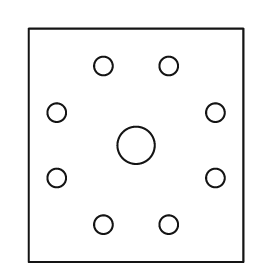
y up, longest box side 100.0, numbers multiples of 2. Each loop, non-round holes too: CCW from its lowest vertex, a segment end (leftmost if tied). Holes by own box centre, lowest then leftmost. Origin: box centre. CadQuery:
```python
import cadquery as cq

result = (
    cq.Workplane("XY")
    .moveTo(-46.0, -50.0)
    .lineTo(46.0, -50.0)
    .lineTo(46.0, 50.0)
    .lineTo(-46.0, 50.0)
    .close()
    .moveTo(-14.0, -34.0)
    .circle(4.0)
    .moveTo(14.0, -34.0)
    .circle(4.0)
    .moveTo(-34.0, -14.0)
    .circle(4.0)
    .moveTo(34.0, -14.0)
    .circle(4.0)
    .moveTo(0.0, 0.0)
    .circle(8.0)
    .moveTo(-34.0, 14.0)
    .circle(4.0)
    .moveTo(34.0, 14.0)
    .circle(4.0)
    .moveTo(-14.0, 34.0)
    .circle(4.0)
    .moveTo(14.0, 34.0)
    .circle(4.0)
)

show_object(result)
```